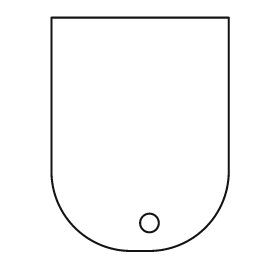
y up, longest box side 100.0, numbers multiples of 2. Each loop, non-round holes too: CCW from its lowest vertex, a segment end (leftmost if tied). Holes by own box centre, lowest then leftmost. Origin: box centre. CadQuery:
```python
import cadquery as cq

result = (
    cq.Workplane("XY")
    .moveTo(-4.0, -50.0)
    .lineTo(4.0, -50.0)
    .threePointArc((28.0, -40.0), (38.0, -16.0))
    .lineTo(38.0, 50.0)
    .lineTo(-38.0, 50.0)
    .lineTo(-38.0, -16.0)
    .threePointArc((-28.0, -40.0), (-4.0, -50.0))
    .close()
    .moveTo(4.0, -38.0)
    .circle(4.0)
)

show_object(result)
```